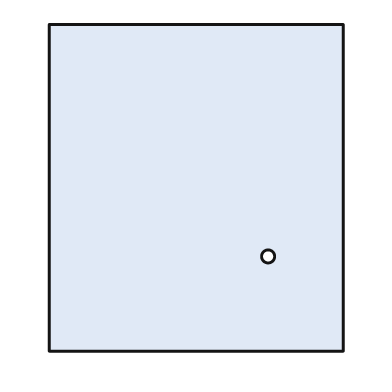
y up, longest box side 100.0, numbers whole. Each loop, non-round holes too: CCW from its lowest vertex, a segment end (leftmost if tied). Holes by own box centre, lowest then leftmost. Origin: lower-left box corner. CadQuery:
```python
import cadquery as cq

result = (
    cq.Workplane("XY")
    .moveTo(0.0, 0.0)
    .lineTo(90.0, 0.0)
    .lineTo(90.0, 100.0)
    .lineTo(0.0, 100.0)
    .close()
    .moveTo(67.0, 29.0)
    .circle(2.0)
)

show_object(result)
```